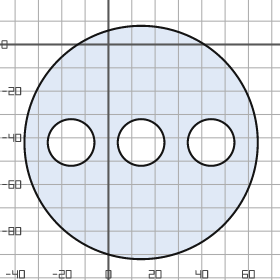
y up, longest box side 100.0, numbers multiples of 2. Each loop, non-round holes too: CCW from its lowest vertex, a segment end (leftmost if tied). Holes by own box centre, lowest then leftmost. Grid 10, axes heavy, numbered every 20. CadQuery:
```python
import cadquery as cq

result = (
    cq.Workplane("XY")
    .moveTo(14.0, -42.0)
    .circle(50.0)
    .moveTo(-16.0, -42.0)
    .circle(10.0)
    .moveTo(14.0, -42.0)
    .circle(10.0)
    .moveTo(44.0, -42.0)
    .circle(10.0)
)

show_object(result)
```